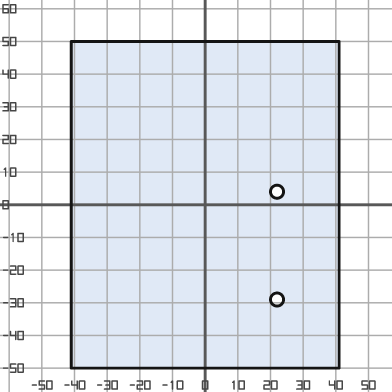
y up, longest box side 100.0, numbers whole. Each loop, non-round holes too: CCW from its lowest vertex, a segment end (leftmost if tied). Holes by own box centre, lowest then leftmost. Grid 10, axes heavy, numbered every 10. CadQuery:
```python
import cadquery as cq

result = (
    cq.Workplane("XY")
    .moveTo(-41.0, -50.0)
    .lineTo(41.0, -50.0)
    .lineTo(41.0, 50.0)
    .lineTo(-41.0, 50.0)
    .close()
    .moveTo(22.0, -29.0)
    .circle(2.0)
    .moveTo(22.0, 4.0)
    .circle(2.0)
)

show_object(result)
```